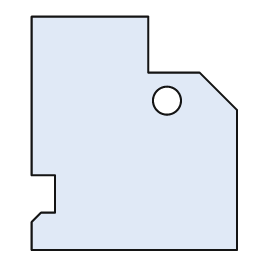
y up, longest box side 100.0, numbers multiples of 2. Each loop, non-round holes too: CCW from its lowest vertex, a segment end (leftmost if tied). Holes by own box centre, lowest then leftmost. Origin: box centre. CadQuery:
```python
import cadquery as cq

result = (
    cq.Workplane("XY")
    .moveTo(-44.0, -50.0)
    .lineTo(44.0, -50.0)
    .lineTo(44.0, 10.0)
    .lineTo(28.0, 26.0)
    .lineTo(6.0, 26.0)
    .lineTo(6.0, 50.0)
    .lineTo(-44.0, 50.0)
    .lineTo(-44.0, -18.0)
    .lineTo(-34.0, -18.0)
    .lineTo(-34.0, -34.0)
    .lineTo(-40.0, -34.0)
    .lineTo(-44.0, -38.0)
    .close()
    .moveTo(14.0, 14.0)
    .circle(6.0)
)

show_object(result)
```